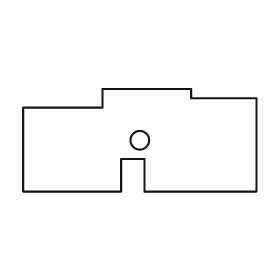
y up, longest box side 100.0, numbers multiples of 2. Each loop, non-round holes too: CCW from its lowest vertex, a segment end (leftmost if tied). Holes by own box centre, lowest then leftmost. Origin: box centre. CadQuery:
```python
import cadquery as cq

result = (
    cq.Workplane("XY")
    .moveTo(-50.0, -22.0)
    .lineTo(-8.0, -22.0)
    .lineTo(-8.0, -8.0)
    .lineTo(2.0, -8.0)
    .lineTo(2.0, -22.0)
    .lineTo(50.0, -22.0)
    .lineTo(50.0, 18.0)
    .lineTo(22.0, 18.0)
    .lineTo(22.0, 22.0)
    .lineTo(-16.0, 22.0)
    .lineTo(-16.0, 14.0)
    .lineTo(-50.0, 14.0)
    .close()
    .moveTo(0.0, 0.0)
    .circle(4.0)
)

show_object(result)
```